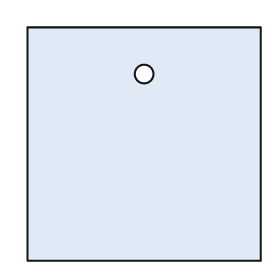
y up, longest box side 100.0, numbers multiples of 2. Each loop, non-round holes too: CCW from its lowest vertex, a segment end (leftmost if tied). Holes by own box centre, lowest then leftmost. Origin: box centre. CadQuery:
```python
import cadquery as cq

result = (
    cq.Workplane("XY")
    .moveTo(-50.0, -50.0)
    .lineTo(50.0, -50.0)
    .lineTo(50.0, 50.0)
    .lineTo(-50.0, 50.0)
    .close()
    .moveTo(0.0, 30.0)
    .circle(4.0)
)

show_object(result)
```